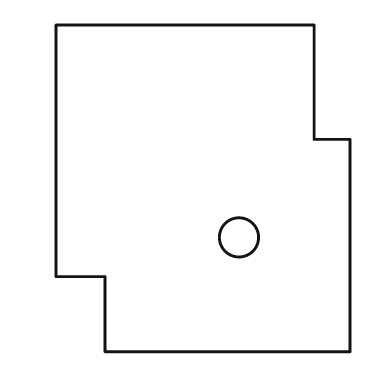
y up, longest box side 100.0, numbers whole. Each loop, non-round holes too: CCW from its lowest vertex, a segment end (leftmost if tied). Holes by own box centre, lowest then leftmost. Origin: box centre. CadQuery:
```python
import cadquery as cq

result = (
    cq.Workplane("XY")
    .moveTo(-30.0, -50.0)
    .lineTo(45.0, -50.0)
    .lineTo(45.0, 15.0)
    .lineTo(34.0, 15.0)
    .lineTo(34.0, 50.0)
    .lineTo(-45.0, 50.0)
    .lineTo(-45.0, -27.0)
    .lineTo(-30.0, -27.0)
    .close()
    .moveTo(11.0, -15.0)
    .circle(6.0)
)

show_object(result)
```